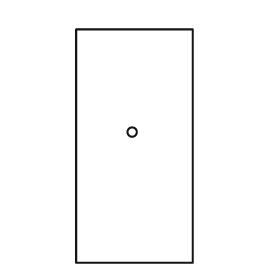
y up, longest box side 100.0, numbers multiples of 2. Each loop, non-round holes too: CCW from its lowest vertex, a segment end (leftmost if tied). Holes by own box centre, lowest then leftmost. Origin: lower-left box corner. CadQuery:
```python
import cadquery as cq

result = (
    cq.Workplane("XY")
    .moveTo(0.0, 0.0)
    .lineTo(50.0, 0.0)
    .lineTo(50.0, 100.0)
    .lineTo(0.0, 100.0)
    .close()
    .moveTo(24.0, 56.0)
    .circle(2.0)
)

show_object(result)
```